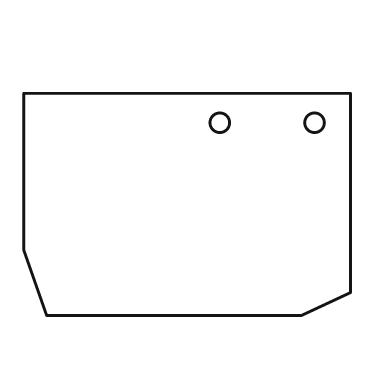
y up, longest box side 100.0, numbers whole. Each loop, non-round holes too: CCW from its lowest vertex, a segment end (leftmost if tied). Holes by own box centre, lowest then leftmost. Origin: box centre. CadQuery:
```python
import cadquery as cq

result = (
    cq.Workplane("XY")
    .moveTo(-43.0, -34.0)
    .lineTo(35.0, -34.0)
    .lineTo(50.0, -27.0)
    .lineTo(50.0, 34.0)
    .lineTo(-50.0, 34.0)
    .lineTo(-50.0, -14.0)
    .close()
    .moveTo(10.0, 25.0)
    .circle(3.0)
    .moveTo(39.0, 25.0)
    .circle(3.0)
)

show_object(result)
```